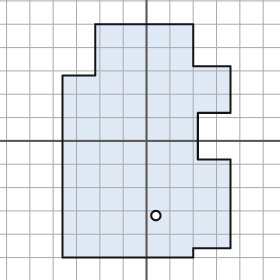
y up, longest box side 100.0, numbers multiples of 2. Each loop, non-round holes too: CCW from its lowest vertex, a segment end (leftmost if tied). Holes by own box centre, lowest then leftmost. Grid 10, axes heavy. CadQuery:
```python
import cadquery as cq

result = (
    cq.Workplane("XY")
    .moveTo(-36.0, -50.0)
    .lineTo(20.0, -50.0)
    .lineTo(20.0, -46.0)
    .lineTo(36.0, -46.0)
    .lineTo(36.0, -8.0)
    .lineTo(22.0, -8.0)
    .lineTo(22.0, 12.0)
    .lineTo(36.0, 12.0)
    .lineTo(36.0, 32.0)
    .lineTo(20.0, 32.0)
    .lineTo(20.0, 50.0)
    .lineTo(-22.0, 50.0)
    .lineTo(-22.0, 28.0)
    .lineTo(-36.0, 28.0)
    .close()
    .moveTo(4.0, -32.0)
    .circle(2.0)
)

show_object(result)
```